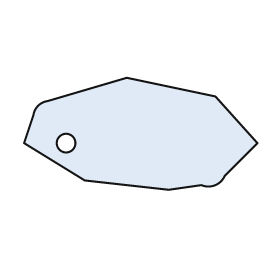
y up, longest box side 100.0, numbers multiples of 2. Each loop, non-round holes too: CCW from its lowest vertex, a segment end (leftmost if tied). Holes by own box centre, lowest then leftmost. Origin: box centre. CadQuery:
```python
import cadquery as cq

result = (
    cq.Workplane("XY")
    .moveTo(12.0, -24.0)
    .lineTo(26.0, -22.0)
    .threePointArc((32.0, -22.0), (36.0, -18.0))
    .lineTo(50.0, -4.0)
    .lineTo(32.0, 16.0)
    .lineTo(-6.0, 24.0)
    .lineTo(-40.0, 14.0)
    .threePointArc((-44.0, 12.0), (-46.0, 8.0))
    .lineTo(-50.0, -4.0)
    .lineTo(-24.0, -20.0)
    .close()
    .moveTo(-32.0, -4.0)
    .circle(4.0)
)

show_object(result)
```